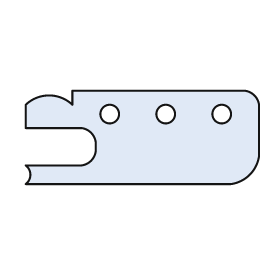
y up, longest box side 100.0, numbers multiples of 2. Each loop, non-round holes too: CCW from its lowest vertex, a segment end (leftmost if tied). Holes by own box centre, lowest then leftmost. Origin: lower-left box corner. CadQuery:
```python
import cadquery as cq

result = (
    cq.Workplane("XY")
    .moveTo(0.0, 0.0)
    .lineTo(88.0, 0.0)
    .threePointArc((96.0, 4.0), (100.0, 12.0))
    .lineTo(100.0, 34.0)
    .threePointArc((98.0, 38.0), (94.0, 40.0))
    .lineTo(20.0, 40.0)
    .lineTo(20.0, 34.0)
    .threePointArc((10.0, 38.0), (0.0, 34.0))
    .lineTo(0.0, 24.0)
    .lineTo(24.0, 24.0)
    .threePointArc((28.0, 22.0), (30.0, 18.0))
    .lineTo(30.0, 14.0)
    .threePointArc((28.0, 10.0), (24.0, 8.0))
    .lineTo(0.0, 8.0)
    .threePointArc((2.0, 4.0), (0.0, 0.0))
    .close()
    .moveTo(36.0, 30.0)
    .circle(4.0)
    .moveTo(60.0, 30.0)
    .circle(4.0)
    .moveTo(84.0, 30.0)
    .circle(4.0)
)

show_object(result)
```